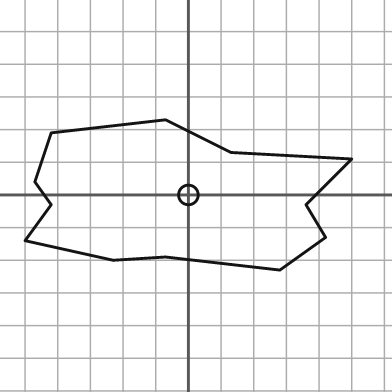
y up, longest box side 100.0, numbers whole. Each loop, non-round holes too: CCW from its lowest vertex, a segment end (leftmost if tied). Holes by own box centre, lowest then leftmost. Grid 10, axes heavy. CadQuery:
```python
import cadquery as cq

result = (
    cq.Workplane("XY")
    .moveTo(28.0, -23.0)
    .lineTo(42.0, -13.0)
    .lineTo(36.0, -3.0)
    .lineTo(50.0, 11.0)
    .lineTo(13.0, 13.0)
    .lineTo(-7.0, 23.0)
    .lineTo(-42.0, 19.0)
    .lineTo(-47.0, 4.0)
    .lineTo(-42.0, -3.0)
    .lineTo(-50.0, -14.0)
    .lineTo(-23.0, -20.0)
    .lineTo(-7.0, -19.0)
    .close()
    .moveTo(0.0, 0.0)
    .circle(3.0)
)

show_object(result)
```